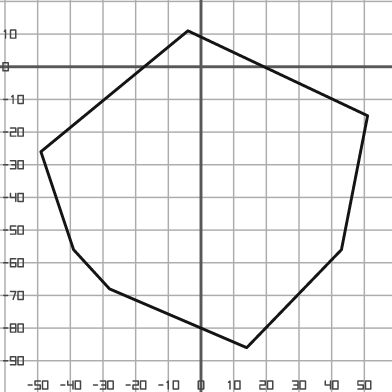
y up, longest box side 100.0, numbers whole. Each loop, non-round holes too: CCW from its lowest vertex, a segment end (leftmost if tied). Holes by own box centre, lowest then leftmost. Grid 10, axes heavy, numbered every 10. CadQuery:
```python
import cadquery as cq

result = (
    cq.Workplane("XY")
    .moveTo(14.0, -86.0)
    .lineTo(43.0, -56.0)
    .lineTo(51.0, -15.0)
    .lineTo(-4.0, 11.0)
    .lineTo(-49.0, -26.0)
    .lineTo(-39.0, -56.0)
    .lineTo(-28.0, -68.0)
    .close()
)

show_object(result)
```